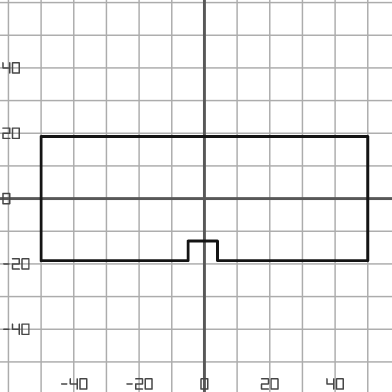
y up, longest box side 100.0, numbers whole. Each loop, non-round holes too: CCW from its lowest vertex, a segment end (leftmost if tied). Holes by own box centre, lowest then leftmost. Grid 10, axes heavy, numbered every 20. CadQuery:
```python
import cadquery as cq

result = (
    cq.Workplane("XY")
    .moveTo(-50.0, -19.0)
    .lineTo(-5.0, -19.0)
    .lineTo(-5.0, -13.0)
    .lineTo(4.0, -13.0)
    .lineTo(4.0, -19.0)
    .lineTo(50.0, -19.0)
    .lineTo(50.0, 19.0)
    .lineTo(-50.0, 19.0)
    .close()
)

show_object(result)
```